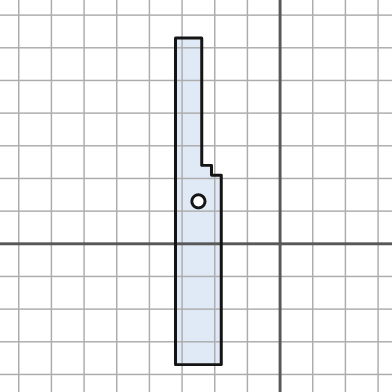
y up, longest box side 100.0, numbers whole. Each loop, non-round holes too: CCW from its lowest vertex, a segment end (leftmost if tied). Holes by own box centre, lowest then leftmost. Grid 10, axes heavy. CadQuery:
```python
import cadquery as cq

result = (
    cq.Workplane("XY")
    .moveTo(-32.0, -37.0)
    .lineTo(-18.0, -37.0)
    .lineTo(-18.0, 21.0)
    .lineTo(-21.0, 21.0)
    .lineTo(-21.0, 24.0)
    .lineTo(-24.0, 24.0)
    .lineTo(-24.0, 63.0)
    .lineTo(-32.0, 63.0)
    .close()
    .moveTo(-25.0, 13.0)
    .circle(2.0)
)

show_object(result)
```